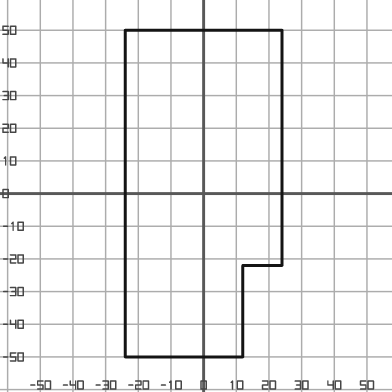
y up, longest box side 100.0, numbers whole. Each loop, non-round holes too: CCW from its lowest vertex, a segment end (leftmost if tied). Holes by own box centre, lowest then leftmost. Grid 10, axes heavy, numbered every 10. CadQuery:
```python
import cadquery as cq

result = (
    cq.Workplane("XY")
    .moveTo(-24.0, -50.0)
    .lineTo(12.0, -50.0)
    .lineTo(12.0, -22.0)
    .lineTo(24.0, -22.0)
    .lineTo(24.0, 50.0)
    .lineTo(-24.0, 50.0)
    .close()
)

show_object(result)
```